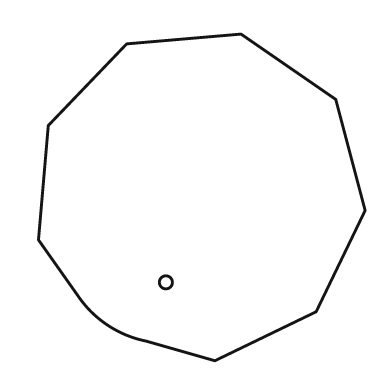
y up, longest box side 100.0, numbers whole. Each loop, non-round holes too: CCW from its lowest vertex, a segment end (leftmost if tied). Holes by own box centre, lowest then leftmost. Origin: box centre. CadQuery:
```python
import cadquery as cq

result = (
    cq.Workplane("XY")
    .moveTo(4.0, -50.0)
    .lineTo(35.0, -35.0)
    .lineTo(50.0, -4.0)
    .lineTo(41.0, 30.0)
    .lineTo(12.0, 50.0)
    .lineTo(-23.0, 47.0)
    .lineTo(-47.0, 22.0)
    .lineTo(-50.0, -13.0)
    .lineTo(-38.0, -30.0)
    .threePointArc((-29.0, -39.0), (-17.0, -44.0))
    .close()
    .moveTo(-11.0, -26.0)
    .circle(2.0)
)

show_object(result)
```